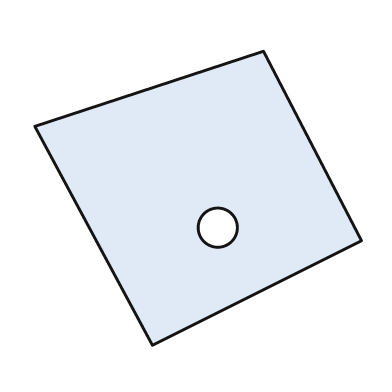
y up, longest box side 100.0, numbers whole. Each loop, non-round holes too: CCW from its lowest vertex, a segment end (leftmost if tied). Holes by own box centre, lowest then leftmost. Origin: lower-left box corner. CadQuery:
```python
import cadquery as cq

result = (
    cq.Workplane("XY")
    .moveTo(36.0, 0.0)
    .lineTo(100.0, 32.0)
    .lineTo(70.0, 90.0)
    .lineTo(0.0, 67.0)
    .close()
    .moveTo(56.0, 36.0)
    .circle(6.0)
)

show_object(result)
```